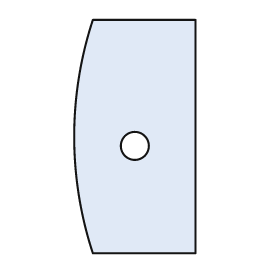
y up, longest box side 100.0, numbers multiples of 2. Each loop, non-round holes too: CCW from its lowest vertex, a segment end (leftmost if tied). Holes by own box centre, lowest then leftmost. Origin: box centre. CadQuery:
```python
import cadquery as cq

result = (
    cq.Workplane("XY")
    .moveTo(-18.0, -50.0)
    .lineTo(26.0, -50.0)
    .lineTo(26.0, 50.0)
    .lineTo(-18.0, 50.0)
    .threePointArc((-26.0, 0.0), (-18.0, -50.0))
    .close()
    .moveTo(0.0, -4.0)
    .circle(6.0)
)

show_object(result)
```